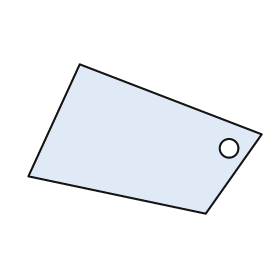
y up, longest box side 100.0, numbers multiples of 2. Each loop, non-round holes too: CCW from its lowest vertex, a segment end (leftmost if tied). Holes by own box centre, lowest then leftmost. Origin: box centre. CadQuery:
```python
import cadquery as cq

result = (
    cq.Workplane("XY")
    .moveTo(26.0, -32.0)
    .lineTo(50.0, 2.0)
    .lineTo(-28.0, 32.0)
    .lineTo(-50.0, -16.0)
    .close()
    .moveTo(36.0, -4.0)
    .circle(4.0)
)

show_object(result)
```